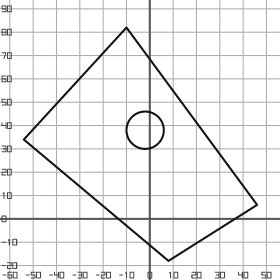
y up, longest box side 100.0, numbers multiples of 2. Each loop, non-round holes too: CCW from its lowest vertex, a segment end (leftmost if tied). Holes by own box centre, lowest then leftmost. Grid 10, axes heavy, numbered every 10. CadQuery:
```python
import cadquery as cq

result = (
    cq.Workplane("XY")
    .moveTo(8.0, -18.0)
    .lineTo(46.0, 6.0)
    .lineTo(-10.0, 82.0)
    .lineTo(-54.0, 34.0)
    .close()
    .moveTo(-2.0, 38.0)
    .circle(8.0)
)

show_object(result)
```